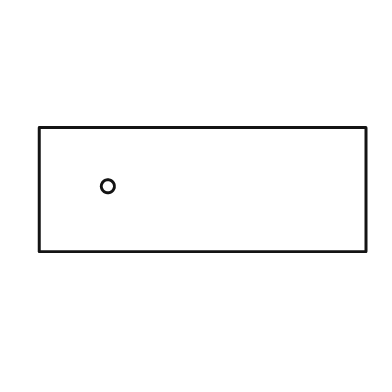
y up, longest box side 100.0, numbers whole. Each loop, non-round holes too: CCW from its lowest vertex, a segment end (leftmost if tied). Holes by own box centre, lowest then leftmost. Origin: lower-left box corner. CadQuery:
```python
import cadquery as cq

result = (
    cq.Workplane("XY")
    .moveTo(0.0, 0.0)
    .lineTo(100.0, 0.0)
    .lineTo(100.0, 38.0)
    .lineTo(0.0, 38.0)
    .close()
    .moveTo(21.0, 20.0)
    .circle(2.0)
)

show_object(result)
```